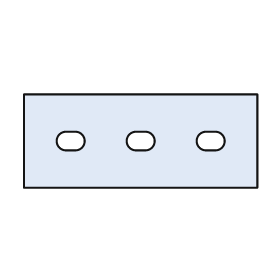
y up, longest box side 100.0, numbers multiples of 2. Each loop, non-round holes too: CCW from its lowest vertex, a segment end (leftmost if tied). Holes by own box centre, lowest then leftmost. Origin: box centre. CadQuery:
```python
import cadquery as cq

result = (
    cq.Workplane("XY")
    .moveTo(-50.0, -20.0)
    .lineTo(50.0, -20.0)
    .lineTo(50.0, 20.0)
    .lineTo(-50.0, 20.0)
    .close()
    .moveTo(-32.0, -4.0)
    .lineTo(-28.0, -4.0)
    .threePointArc((-24.0, 0.0), (-28.0, 4.0))
    .lineTo(-32.0, 4.0)
    .threePointArc((-36.0, 0.0), (-32.0, -4.0))
    .close()
    .moveTo(-2.0, -4.0)
    .lineTo(2.0, -4.0)
    .threePointArc((6.0, 0.0), (2.0, 4.0))
    .lineTo(-2.0, 4.0)
    .threePointArc((-6.0, 0.0), (-2.0, -4.0))
    .close()
    .moveTo(28.0, -4.0)
    .lineTo(32.0, -4.0)
    .threePointArc((36.0, 0.0), (32.0, 4.0))
    .lineTo(28.0, 4.0)
    .threePointArc((24.0, 0.0), (28.0, -4.0))
    .close()
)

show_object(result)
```